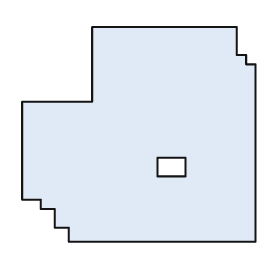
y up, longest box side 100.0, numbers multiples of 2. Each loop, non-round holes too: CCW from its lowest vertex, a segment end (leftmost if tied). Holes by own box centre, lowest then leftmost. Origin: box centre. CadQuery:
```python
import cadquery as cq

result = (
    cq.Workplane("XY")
    .moveTo(-30.0, -46.0)
    .lineTo(50.0, -46.0)
    .lineTo(50.0, 30.0)
    .lineTo(46.0, 30.0)
    .lineTo(46.0, 34.0)
    .lineTo(42.0, 34.0)
    .lineTo(42.0, 46.0)
    .lineTo(-20.0, 46.0)
    .lineTo(-20.0, 14.0)
    .lineTo(-50.0, 14.0)
    .lineTo(-50.0, -28.0)
    .lineTo(-42.0, -28.0)
    .lineTo(-42.0, -32.0)
    .lineTo(-36.0, -32.0)
    .lineTo(-36.0, -40.0)
    .lineTo(-30.0, -40.0)
    .close()
    .moveTo(8.0, -18.0)
    .lineTo(20.0, -18.0)
    .lineTo(20.0, -10.0)
    .lineTo(8.0, -10.0)
    .close()
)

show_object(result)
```